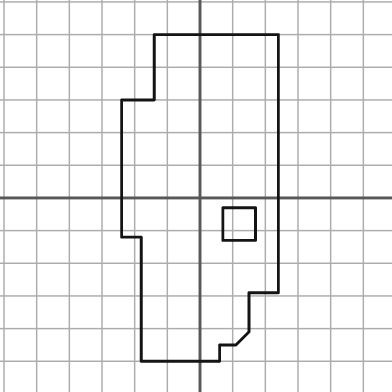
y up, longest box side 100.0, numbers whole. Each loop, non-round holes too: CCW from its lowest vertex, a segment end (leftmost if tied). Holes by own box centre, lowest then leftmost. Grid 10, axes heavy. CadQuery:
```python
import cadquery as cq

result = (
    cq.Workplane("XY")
    .moveTo(-18.0, -50.0)
    .lineTo(6.0, -50.0)
    .lineTo(6.0, -45.0)
    .lineTo(11.0, -45.0)
    .lineTo(15.0, -41.0)
    .lineTo(15.0, -29.0)
    .lineTo(24.0, -29.0)
    .lineTo(24.0, 50.0)
    .lineTo(-14.0, 50.0)
    .lineTo(-14.0, 30.0)
    .lineTo(-24.0, 30.0)
    .lineTo(-24.0, -12.0)
    .lineTo(-18.0, -12.0)
    .close()
    .moveTo(7.0, -13.0)
    .lineTo(17.0, -13.0)
    .lineTo(17.0, -3.0)
    .lineTo(7.0, -3.0)
    .close()
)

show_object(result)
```